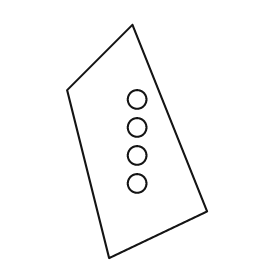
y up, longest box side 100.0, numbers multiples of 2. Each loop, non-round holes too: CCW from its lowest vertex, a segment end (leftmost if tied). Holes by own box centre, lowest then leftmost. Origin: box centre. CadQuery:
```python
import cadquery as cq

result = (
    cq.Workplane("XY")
    .moveTo(-12.0, -50.0)
    .lineTo(30.0, -30.0)
    .lineTo(-2.0, 50.0)
    .lineTo(-30.0, 22.0)
    .close()
    .moveTo(0.0, -18.0)
    .circle(4.0)
    .moveTo(0.0, -6.0)
    .circle(4.0)
    .moveTo(0.0, 6.0)
    .circle(4.0)
    .moveTo(0.0, 18.0)
    .circle(4.0)
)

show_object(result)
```